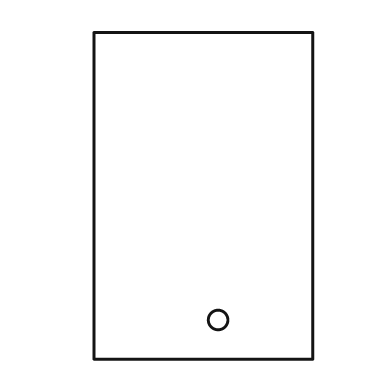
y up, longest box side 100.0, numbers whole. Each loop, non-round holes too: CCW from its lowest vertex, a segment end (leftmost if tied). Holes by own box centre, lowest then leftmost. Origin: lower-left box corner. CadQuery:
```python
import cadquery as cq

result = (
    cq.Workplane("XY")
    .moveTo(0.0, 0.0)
    .lineTo(67.0, 0.0)
    .lineTo(67.0, 100.0)
    .lineTo(0.0, 100.0)
    .close()
    .moveTo(38.0, 12.0)
    .circle(3.0)
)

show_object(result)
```